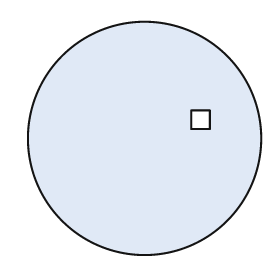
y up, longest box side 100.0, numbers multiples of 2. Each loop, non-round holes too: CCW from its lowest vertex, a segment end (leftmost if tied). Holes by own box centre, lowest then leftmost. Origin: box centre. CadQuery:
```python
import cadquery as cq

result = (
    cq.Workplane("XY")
    .moveTo(0.0, 0.0)
    .circle(50.0)
    .moveTo(20.0, 4.0)
    .lineTo(28.0, 4.0)
    .lineTo(28.0, 12.0)
    .lineTo(20.0, 12.0)
    .close()
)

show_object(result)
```